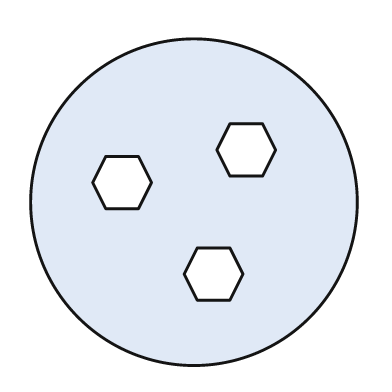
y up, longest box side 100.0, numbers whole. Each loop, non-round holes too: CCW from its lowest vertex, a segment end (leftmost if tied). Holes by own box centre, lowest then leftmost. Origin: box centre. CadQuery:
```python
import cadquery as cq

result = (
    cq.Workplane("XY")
    .moveTo(0.0, 0.0)
    .circle(50.0)
    .moveTo(1.0, -30.0)
    .lineTo(11.0, -30.0)
    .lineTo(15.0, -22.0)
    .lineTo(11.0, -14.0)
    .lineTo(1.0, -14.0)
    .lineTo(-3.0, -22.0)
    .close()
    .moveTo(-27.0, -2.0)
    .lineTo(-17.0, -2.0)
    .lineTo(-13.0, 6.0)
    .lineTo(-17.0, 14.0)
    .lineTo(-27.0, 14.0)
    .lineTo(-31.0, 6.0)
    .close()
    .moveTo(11.0, 8.0)
    .lineTo(21.0, 8.0)
    .lineTo(25.0, 16.0)
    .lineTo(21.0, 24.0)
    .lineTo(11.0, 24.0)
    .lineTo(7.0, 16.0)
    .close()
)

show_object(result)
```